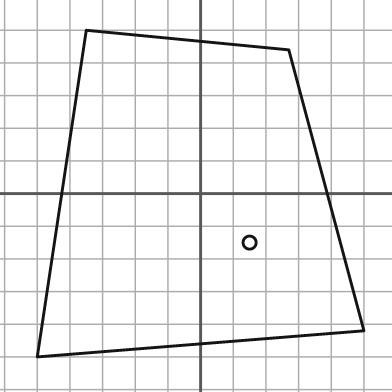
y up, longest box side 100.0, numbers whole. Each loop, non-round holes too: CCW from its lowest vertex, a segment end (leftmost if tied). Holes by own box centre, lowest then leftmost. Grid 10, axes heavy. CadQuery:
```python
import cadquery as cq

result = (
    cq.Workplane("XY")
    .moveTo(-50.0, -50.0)
    .lineTo(50.0, -42.0)
    .lineTo(27.0, 44.0)
    .lineTo(-35.0, 50.0)
    .close()
    .moveTo(15.0, -15.0)
    .circle(2.0)
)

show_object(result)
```